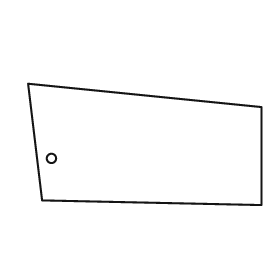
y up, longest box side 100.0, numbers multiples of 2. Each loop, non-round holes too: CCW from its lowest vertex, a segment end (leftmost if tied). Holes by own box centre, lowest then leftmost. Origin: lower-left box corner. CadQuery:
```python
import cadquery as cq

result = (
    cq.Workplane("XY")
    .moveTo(100.0, 0.0)
    .lineTo(100.0, 42.0)
    .lineTo(0.0, 52.0)
    .lineTo(6.0, 2.0)
    .close()
    .moveTo(10.0, 20.0)
    .circle(2.0)
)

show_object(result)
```